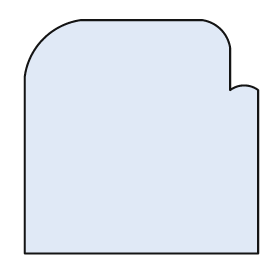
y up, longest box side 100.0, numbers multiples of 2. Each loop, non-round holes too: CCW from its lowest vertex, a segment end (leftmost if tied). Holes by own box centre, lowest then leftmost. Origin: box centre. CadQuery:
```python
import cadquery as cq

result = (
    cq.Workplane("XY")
    .moveTo(-50.0, -50.0)
    .lineTo(50.0, -50.0)
    .lineTo(50.0, 20.0)
    .threePointArc((44.0, 22.0), (38.0, 20.0))
    .lineTo(38.0, 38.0)
    .threePointArc((34.0, 46.0), (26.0, 50.0))
    .lineTo(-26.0, 50.0)
    .threePointArc((-42.0, 42.0), (-50.0, 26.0))
    .close()
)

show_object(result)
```